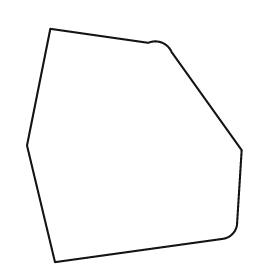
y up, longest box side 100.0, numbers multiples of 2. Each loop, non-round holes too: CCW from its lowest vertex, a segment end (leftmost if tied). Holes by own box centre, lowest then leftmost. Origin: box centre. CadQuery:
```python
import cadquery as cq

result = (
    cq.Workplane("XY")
    .moveTo(-34.0, -50.0)
    .lineTo(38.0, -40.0)
    .threePointArc((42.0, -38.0), (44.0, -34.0))
    .lineTo(46.0, -2.0)
    .lineTo(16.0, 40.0)
    .threePointArc((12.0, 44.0), (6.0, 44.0))
    .lineTo(-36.0, 50.0)
    .lineTo(-46.0, 0.0)
    .close()
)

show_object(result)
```